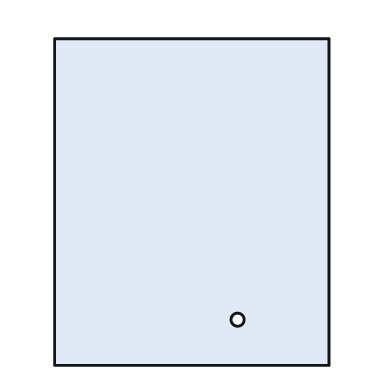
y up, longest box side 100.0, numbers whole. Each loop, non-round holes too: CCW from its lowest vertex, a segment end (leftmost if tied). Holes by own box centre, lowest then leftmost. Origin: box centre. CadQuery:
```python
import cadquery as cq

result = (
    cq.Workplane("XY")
    .moveTo(-42.0, -50.0)
    .lineTo(42.0, -50.0)
    .lineTo(42.0, 50.0)
    .lineTo(-42.0, 50.0)
    .close()
    .moveTo(14.0, -36.0)
    .circle(2.0)
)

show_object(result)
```